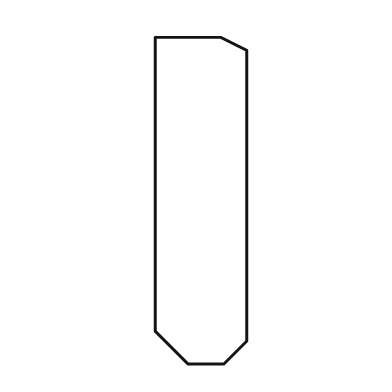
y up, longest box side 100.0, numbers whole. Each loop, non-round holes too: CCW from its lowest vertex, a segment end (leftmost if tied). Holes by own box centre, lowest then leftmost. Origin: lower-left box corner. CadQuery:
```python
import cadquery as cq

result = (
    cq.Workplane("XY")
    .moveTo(10.0, 0.0)
    .lineTo(21.0, 0.0)
    .lineTo(28.0, 7.0)
    .lineTo(28.0, 96.0)
    .lineTo(20.0, 100.0)
    .lineTo(0.0, 100.0)
    .lineTo(0.0, 10.0)
    .close()
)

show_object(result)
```